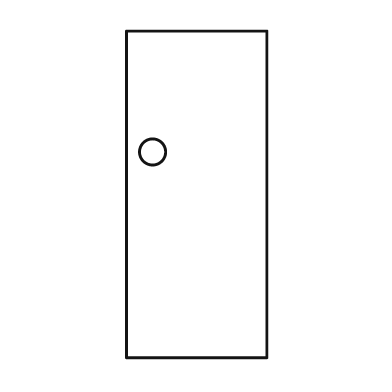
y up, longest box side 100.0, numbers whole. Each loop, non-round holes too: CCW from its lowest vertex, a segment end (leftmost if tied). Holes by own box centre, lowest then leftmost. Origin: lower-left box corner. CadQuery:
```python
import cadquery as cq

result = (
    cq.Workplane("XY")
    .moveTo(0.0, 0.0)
    .lineTo(43.0, 0.0)
    .lineTo(43.0, 100.0)
    .lineTo(0.0, 100.0)
    .close()
    .moveTo(8.0, 63.0)
    .circle(4.0)
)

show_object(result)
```